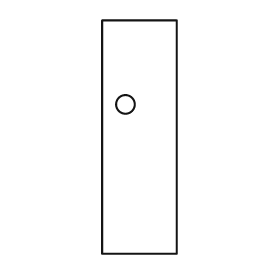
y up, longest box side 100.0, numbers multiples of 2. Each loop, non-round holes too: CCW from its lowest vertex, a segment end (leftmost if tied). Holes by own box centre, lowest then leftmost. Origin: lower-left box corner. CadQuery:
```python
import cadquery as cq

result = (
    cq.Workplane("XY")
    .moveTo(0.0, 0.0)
    .lineTo(32.0, 0.0)
    .lineTo(32.0, 100.0)
    .lineTo(0.0, 100.0)
    .close()
    .moveTo(10.0, 64.0)
    .circle(4.0)
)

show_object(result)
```